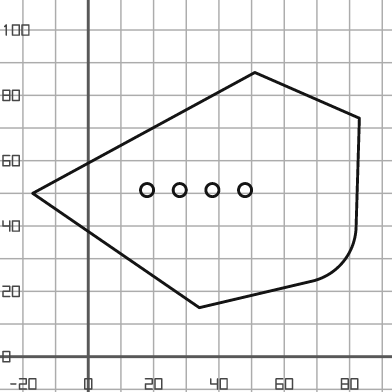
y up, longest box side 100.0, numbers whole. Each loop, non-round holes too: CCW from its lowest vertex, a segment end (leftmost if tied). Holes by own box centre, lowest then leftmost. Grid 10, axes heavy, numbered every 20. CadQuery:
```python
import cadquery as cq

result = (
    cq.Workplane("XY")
    .moveTo(34.0, 15.0)
    .lineTo(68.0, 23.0)
    .threePointArc((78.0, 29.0), (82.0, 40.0))
    .lineTo(83.0, 73.0)
    .lineTo(51.0, 87.0)
    .lineTo(-17.0, 50.0)
    .close()
    .moveTo(18.0, 51.0)
    .circle(2.0)
    .moveTo(28.0, 51.0)
    .circle(2.0)
    .moveTo(38.0, 51.0)
    .circle(2.0)
    .moveTo(48.0, 51.0)
    .circle(2.0)
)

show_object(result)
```